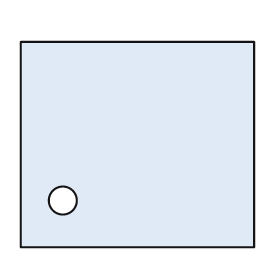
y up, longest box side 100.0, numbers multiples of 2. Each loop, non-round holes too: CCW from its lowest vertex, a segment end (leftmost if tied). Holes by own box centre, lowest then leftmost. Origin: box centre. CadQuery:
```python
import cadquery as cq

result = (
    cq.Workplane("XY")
    .moveTo(-50.0, -44.0)
    .lineTo(50.0, -44.0)
    .lineTo(50.0, 44.0)
    .lineTo(-50.0, 44.0)
    .close()
    .moveTo(-32.0, -24.0)
    .circle(6.0)
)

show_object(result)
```